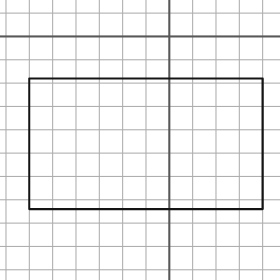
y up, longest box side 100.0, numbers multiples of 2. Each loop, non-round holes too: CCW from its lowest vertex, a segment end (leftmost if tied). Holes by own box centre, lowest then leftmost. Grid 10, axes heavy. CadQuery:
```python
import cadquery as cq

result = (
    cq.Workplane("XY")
    .moveTo(-60.0, -74.0)
    .lineTo(40.0, -74.0)
    .lineTo(40.0, -18.0)
    .lineTo(-60.0, -18.0)
    .close()
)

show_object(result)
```